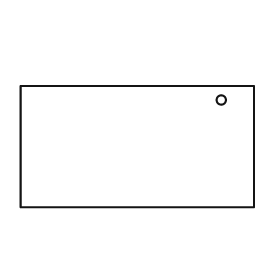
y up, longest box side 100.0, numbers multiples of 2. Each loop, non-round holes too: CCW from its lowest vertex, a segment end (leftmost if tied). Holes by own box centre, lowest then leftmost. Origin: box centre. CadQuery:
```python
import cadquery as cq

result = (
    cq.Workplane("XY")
    .moveTo(-50.0, -26.0)
    .lineTo(50.0, -26.0)
    .lineTo(50.0, 26.0)
    .lineTo(-50.0, 26.0)
    .close()
    .moveTo(36.0, 20.0)
    .circle(2.0)
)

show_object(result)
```